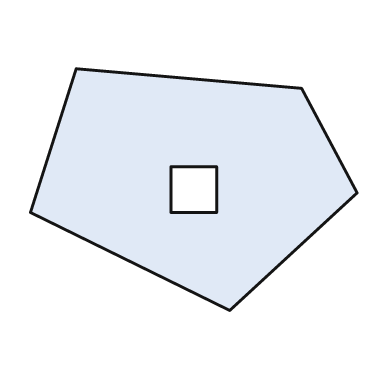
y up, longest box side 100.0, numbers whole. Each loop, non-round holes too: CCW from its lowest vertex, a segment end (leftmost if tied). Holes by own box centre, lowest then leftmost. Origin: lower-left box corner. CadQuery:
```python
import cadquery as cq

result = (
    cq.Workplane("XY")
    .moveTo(61.0, 0.0)
    .lineTo(100.0, 36.0)
    .lineTo(83.0, 68.0)
    .lineTo(14.0, 74.0)
    .lineTo(0.0, 30.0)
    .close()
    .moveTo(43.0, 30.0)
    .lineTo(57.0, 30.0)
    .lineTo(57.0, 44.0)
    .lineTo(43.0, 44.0)
    .close()
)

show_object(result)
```